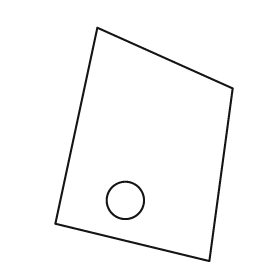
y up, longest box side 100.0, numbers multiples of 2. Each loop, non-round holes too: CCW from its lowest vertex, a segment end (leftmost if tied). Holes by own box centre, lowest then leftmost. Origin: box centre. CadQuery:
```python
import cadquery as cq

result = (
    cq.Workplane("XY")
    .moveTo(28.0, -50.0)
    .lineTo(38.0, 24.0)
    .lineTo(-20.0, 50.0)
    .lineTo(-38.0, -34.0)
    .close()
    .moveTo(-8.0, -24.0)
    .circle(8.0)
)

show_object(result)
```